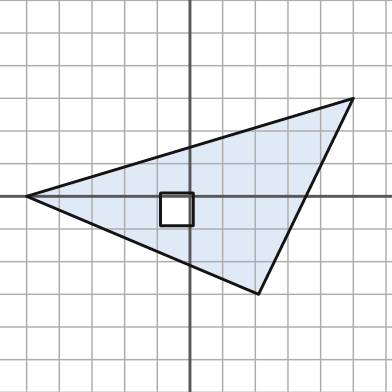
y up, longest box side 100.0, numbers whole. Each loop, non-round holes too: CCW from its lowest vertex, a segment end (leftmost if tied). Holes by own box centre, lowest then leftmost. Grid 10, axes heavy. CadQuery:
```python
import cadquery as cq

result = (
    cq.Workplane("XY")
    .moveTo(21.0, -30.0)
    .lineTo(50.0, 30.0)
    .lineTo(-50.0, 0.0)
    .close()
    .moveTo(-9.0, -9.0)
    .lineTo(1.0, -9.0)
    .lineTo(1.0, 1.0)
    .lineTo(-9.0, 1.0)
    .close()
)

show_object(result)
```